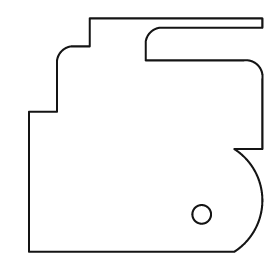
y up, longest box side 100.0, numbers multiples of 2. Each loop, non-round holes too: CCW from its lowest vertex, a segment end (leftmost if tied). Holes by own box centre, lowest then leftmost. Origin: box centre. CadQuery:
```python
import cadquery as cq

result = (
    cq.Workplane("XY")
    .moveTo(-50.0, -50.0)
    .lineTo(38.0, -50.0)
    .threePointArc((50.0, -28.0), (38.0, -6.0))
    .lineTo(50.0, -6.0)
    .lineTo(50.0, 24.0)
    .threePointArc((48.0, 30.0), (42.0, 32.0))
    .lineTo(0.0, 32.0)
    .lineTo(0.0, 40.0)
    .threePointArc((2.0, 44.0), (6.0, 46.0))
    .lineTo(50.0, 46.0)
    .lineTo(50.0, 50.0)
    .lineTo(-24.0, 50.0)
    .lineTo(-24.0, 38.0)
    .lineTo(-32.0, 38.0)
    .threePointArc((-36.0, 36.0), (-38.0, 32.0))
    .lineTo(-38.0, 10.0)
    .lineTo(-50.0, 10.0)
    .close()
    .moveTo(24.0, -34.0)
    .circle(4.0)
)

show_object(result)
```